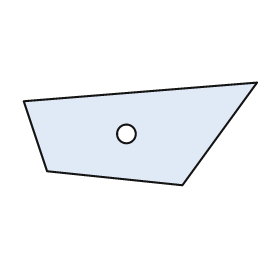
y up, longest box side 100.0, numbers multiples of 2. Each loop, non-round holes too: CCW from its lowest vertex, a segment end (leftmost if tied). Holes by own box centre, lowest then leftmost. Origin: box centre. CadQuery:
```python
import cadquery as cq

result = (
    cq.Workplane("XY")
    .moveTo(18.0, -22.0)
    .lineTo(50.0, 22.0)
    .lineTo(-50.0, 14.0)
    .lineTo(-40.0, -16.0)
    .close()
    .moveTo(-6.0, 0.0)
    .circle(4.0)
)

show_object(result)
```